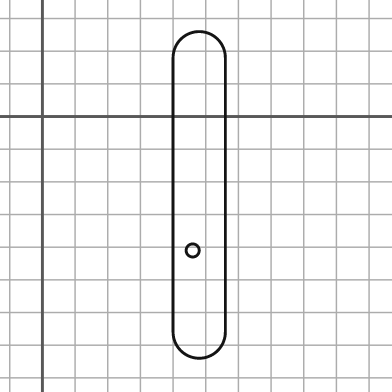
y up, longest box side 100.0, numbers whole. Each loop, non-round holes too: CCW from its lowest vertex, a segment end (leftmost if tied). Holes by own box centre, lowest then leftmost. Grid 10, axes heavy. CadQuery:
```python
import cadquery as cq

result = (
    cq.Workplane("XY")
    .moveTo(40.0, -66.0)
    .threePointArc((48.0, -74.0), (56.0, -66.0))
    .lineTo(56.0, 18.0)
    .threePointArc((48.0, 26.0), (40.0, 18.0))
    .close()
    .moveTo(46.0, -41.0)
    .circle(2.0)
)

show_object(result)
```